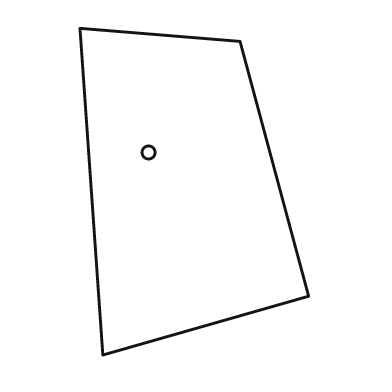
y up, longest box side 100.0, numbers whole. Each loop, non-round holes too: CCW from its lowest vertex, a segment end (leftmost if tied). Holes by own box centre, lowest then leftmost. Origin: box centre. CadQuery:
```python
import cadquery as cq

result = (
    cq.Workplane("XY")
    .moveTo(-28.0, -50.0)
    .lineTo(35.0, -32.0)
    .lineTo(14.0, 46.0)
    .lineTo(-35.0, 50.0)
    .close()
    .moveTo(-14.0, 12.0)
    .circle(2.0)
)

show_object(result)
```